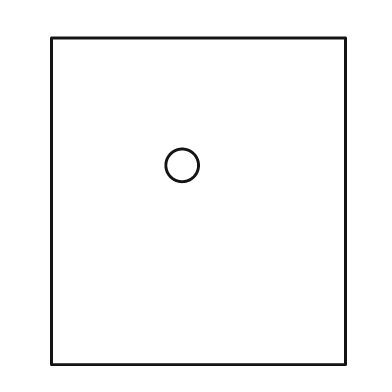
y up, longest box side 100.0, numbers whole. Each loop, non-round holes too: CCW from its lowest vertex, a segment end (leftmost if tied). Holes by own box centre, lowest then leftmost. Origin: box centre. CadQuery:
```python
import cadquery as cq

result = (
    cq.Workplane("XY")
    .moveTo(-45.0, -50.0)
    .lineTo(45.0, -50.0)
    .lineTo(45.0, 50.0)
    .lineTo(-45.0, 50.0)
    .close()
    .moveTo(-5.0, 11.0)
    .circle(5.0)
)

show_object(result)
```